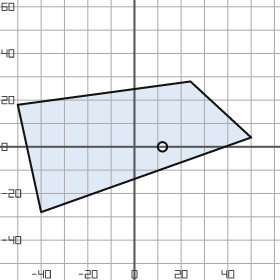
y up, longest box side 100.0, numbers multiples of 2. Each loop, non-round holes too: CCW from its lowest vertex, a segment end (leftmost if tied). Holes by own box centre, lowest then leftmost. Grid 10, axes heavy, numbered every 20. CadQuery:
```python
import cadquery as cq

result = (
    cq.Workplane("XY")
    .moveTo(-40.0, -28.0)
    .lineTo(50.0, 4.0)
    .lineTo(24.0, 28.0)
    .lineTo(-50.0, 18.0)
    .close()
    .moveTo(12.0, 0.0)
    .circle(2.0)
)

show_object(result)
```